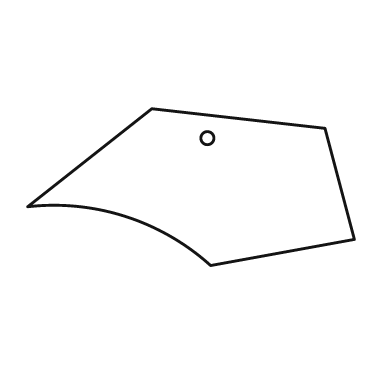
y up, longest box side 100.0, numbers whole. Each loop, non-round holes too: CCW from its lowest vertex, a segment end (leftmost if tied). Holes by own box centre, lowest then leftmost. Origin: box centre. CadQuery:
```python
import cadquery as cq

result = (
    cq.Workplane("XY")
    .moveTo(6.0, -24.0)
    .lineTo(50.0, -16.0)
    .lineTo(41.0, 18.0)
    .lineTo(-12.0, 24.0)
    .lineTo(-50.0, -6.0)
    .threePointArc((-20.0, -9.0), (6.0, -24.0))
    .close()
    .moveTo(5.0, 15.0)
    .circle(2.0)
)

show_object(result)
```